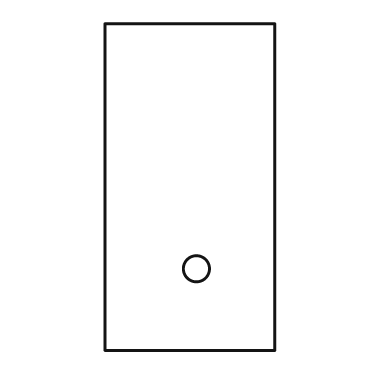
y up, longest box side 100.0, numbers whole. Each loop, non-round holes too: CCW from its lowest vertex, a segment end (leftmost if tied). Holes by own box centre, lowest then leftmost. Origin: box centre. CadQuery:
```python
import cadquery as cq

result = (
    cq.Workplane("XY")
    .moveTo(-26.0, -50.0)
    .lineTo(26.0, -50.0)
    .lineTo(26.0, 50.0)
    .lineTo(-26.0, 50.0)
    .close()
    .moveTo(2.0, -25.0)
    .circle(4.0)
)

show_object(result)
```